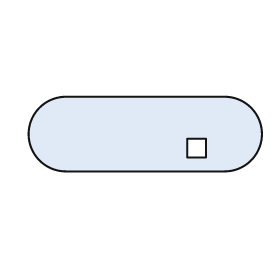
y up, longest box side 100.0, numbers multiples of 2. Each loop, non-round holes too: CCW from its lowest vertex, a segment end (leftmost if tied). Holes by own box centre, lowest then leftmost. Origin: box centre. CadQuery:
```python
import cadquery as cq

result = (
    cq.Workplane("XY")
    .moveTo(-34.0, -16.0)
    .lineTo(34.0, -16.0)
    .threePointArc((50.0, 0.0), (34.0, 16.0))
    .lineTo(-34.0, 16.0)
    .threePointArc((-50.0, 0.0), (-34.0, -16.0))
    .close()
    .moveTo(18.0, -10.0)
    .lineTo(26.0, -10.0)
    .lineTo(26.0, -2.0)
    .lineTo(18.0, -2.0)
    .close()
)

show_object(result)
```